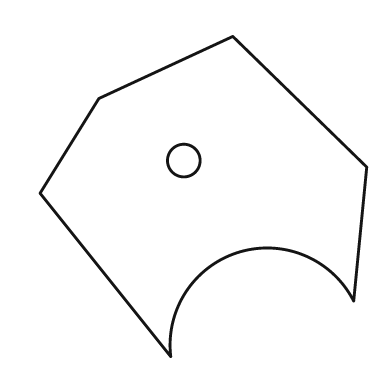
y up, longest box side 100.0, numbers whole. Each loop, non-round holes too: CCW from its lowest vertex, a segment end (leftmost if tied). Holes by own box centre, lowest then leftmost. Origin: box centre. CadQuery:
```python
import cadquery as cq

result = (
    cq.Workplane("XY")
    .moveTo(-10.0, -49.0)
    .threePointArc((11.0, -17.0), (46.0, -32.0))
    .lineTo(50.0, 9.0)
    .lineTo(9.0, 49.0)
    .lineTo(-32.0, 30.0)
    .lineTo(-50.0, 1.0)
    .close()
    .moveTo(-6.0, 11.0)
    .circle(5.0)
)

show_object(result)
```